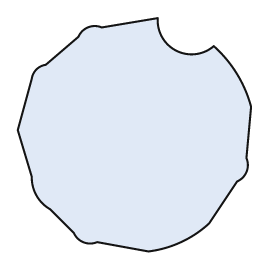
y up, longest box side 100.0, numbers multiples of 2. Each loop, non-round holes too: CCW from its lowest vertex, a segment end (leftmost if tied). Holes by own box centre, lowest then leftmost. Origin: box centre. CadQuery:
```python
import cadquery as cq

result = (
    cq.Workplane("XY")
    .moveTo(6.0, -50.0)
    .threePointArc((20.0, -46.0), (32.0, -38.0))
    .lineTo(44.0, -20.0)
    .threePointArc((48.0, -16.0), (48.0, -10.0))
    .lineTo(50.0, 12.0)
    .threePointArc((44.0, 26.0), (34.0, 38.0))
    .threePointArc((18.0, 36.0), (10.0, 50.0))
    .lineTo(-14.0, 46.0)
    .threePointArc((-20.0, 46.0), (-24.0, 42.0))
    .lineTo(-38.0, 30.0)
    .threePointArc((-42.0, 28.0), (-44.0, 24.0))
    .lineTo(-50.0, 2.0)
    .lineTo(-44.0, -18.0)
    .threePointArc((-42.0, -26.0), (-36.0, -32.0))
    .lineTo(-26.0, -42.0)
    .threePointArc((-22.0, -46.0), (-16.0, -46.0))
    .close()
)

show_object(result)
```